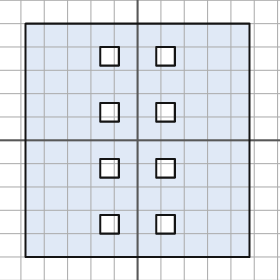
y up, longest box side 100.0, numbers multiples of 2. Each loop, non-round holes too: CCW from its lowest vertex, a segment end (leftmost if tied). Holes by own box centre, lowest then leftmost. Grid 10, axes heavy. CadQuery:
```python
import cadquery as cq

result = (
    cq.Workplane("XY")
    .moveTo(-48.0, -50.0)
    .lineTo(48.0, -50.0)
    .lineTo(48.0, 50.0)
    .lineTo(-48.0, 50.0)
    .close()
    .moveTo(-16.0, -40.0)
    .lineTo(-8.0, -40.0)
    .lineTo(-8.0, -32.0)
    .lineTo(-16.0, -32.0)
    .close()
    .moveTo(8.0, -40.0)
    .lineTo(16.0, -40.0)
    .lineTo(16.0, -32.0)
    .lineTo(8.0, -32.0)
    .close()
    .moveTo(-16.0, -16.0)
    .lineTo(-8.0, -16.0)
    .lineTo(-8.0, -8.0)
    .lineTo(-16.0, -8.0)
    .close()
    .moveTo(8.0, -16.0)
    .lineTo(16.0, -16.0)
    .lineTo(16.0, -8.0)
    .lineTo(8.0, -8.0)
    .close()
    .moveTo(-16.0, 8.0)
    .lineTo(-8.0, 8.0)
    .lineTo(-8.0, 16.0)
    .lineTo(-16.0, 16.0)
    .close()
    .moveTo(8.0, 8.0)
    .lineTo(16.0, 8.0)
    .lineTo(16.0, 16.0)
    .lineTo(8.0, 16.0)
    .close()
    .moveTo(-16.0, 32.0)
    .lineTo(-8.0, 32.0)
    .lineTo(-8.0, 40.0)
    .lineTo(-16.0, 40.0)
    .close()
    .moveTo(8.0, 32.0)
    .lineTo(16.0, 32.0)
    .lineTo(16.0, 40.0)
    .lineTo(8.0, 40.0)
    .close()
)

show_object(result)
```